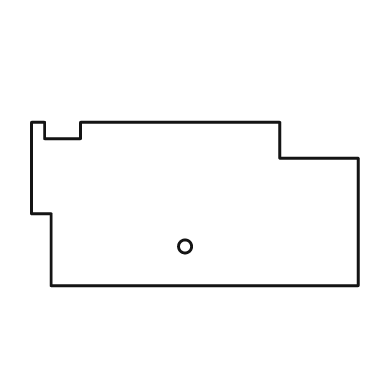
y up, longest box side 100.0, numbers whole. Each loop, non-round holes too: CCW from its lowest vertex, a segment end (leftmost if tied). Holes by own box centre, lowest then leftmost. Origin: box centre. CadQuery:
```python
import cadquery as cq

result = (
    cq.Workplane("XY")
    .moveTo(-44.0, -25.0)
    .lineTo(50.0, -25.0)
    .lineTo(50.0, 14.0)
    .lineTo(26.0, 14.0)
    .lineTo(26.0, 25.0)
    .lineTo(-35.0, 25.0)
    .lineTo(-35.0, 20.0)
    .lineTo(-46.0, 20.0)
    .lineTo(-46.0, 25.0)
    .lineTo(-50.0, 25.0)
    .lineTo(-50.0, -3.0)
    .lineTo(-44.0, -3.0)
    .close()
    .moveTo(-3.0, -13.0)
    .circle(2.0)
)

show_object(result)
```